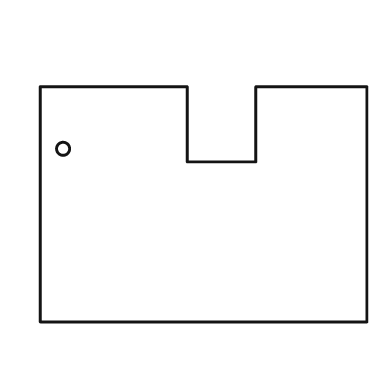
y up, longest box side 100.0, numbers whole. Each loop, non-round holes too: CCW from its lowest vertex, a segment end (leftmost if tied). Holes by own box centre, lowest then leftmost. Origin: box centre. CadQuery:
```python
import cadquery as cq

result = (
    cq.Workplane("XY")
    .moveTo(-50.0, -36.0)
    .lineTo(50.0, -36.0)
    .lineTo(50.0, 36.0)
    .lineTo(16.0, 36.0)
    .lineTo(16.0, 13.0)
    .lineTo(-5.0, 13.0)
    .lineTo(-5.0, 36.0)
    .lineTo(-50.0, 36.0)
    .close()
    .moveTo(-43.0, 17.0)
    .circle(2.0)
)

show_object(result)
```